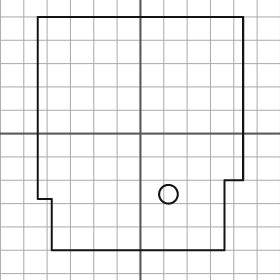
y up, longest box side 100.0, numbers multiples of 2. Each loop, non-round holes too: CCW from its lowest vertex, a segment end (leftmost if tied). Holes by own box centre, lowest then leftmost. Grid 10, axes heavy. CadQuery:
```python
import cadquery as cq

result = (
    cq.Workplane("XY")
    .moveTo(-38.0, -50.0)
    .lineTo(36.0, -50.0)
    .lineTo(36.0, -20.0)
    .lineTo(44.0, -20.0)
    .lineTo(44.0, 50.0)
    .lineTo(-44.0, 50.0)
    .lineTo(-44.0, -28.0)
    .lineTo(-38.0, -28.0)
    .close()
    .moveTo(12.0, -26.0)
    .circle(4.0)
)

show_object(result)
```